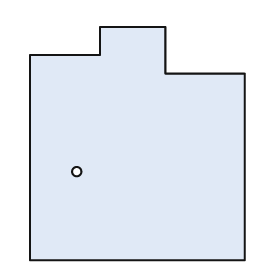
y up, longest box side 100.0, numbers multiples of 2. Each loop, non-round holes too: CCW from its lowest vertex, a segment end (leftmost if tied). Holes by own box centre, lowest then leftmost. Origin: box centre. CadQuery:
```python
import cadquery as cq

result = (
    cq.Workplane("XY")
    .moveTo(-46.0, -50.0)
    .lineTo(46.0, -50.0)
    .lineTo(46.0, 30.0)
    .lineTo(12.0, 30.0)
    .lineTo(12.0, 50.0)
    .lineTo(-16.0, 50.0)
    .lineTo(-16.0, 38.0)
    .lineTo(-46.0, 38.0)
    .close()
    .moveTo(-26.0, -12.0)
    .circle(2.0)
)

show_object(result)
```